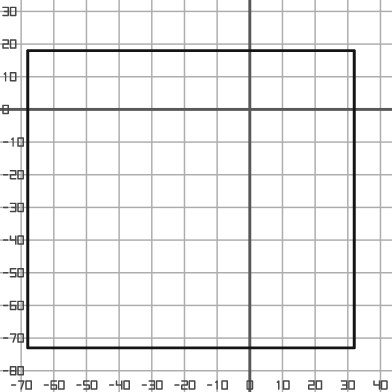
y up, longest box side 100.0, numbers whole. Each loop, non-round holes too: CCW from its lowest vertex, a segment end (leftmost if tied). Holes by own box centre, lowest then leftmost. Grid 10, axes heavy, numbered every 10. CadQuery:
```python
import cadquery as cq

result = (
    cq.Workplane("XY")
    .moveTo(-68.0, -73.0)
    .lineTo(32.0, -73.0)
    .lineTo(32.0, 18.0)
    .lineTo(-68.0, 18.0)
    .close()
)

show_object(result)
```